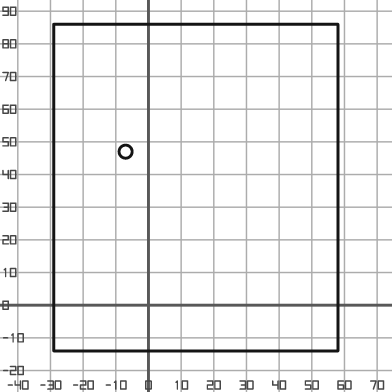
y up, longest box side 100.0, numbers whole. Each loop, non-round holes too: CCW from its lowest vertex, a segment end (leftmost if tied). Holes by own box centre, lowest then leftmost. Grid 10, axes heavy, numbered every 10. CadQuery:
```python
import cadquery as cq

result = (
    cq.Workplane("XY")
    .moveTo(-29.0, -14.0)
    .lineTo(58.0, -14.0)
    .lineTo(58.0, 86.0)
    .lineTo(-29.0, 86.0)
    .close()
    .moveTo(-7.0, 47.0)
    .circle(2.0)
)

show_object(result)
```